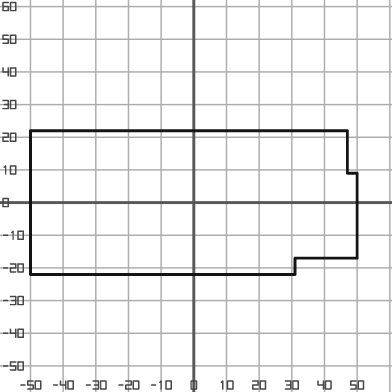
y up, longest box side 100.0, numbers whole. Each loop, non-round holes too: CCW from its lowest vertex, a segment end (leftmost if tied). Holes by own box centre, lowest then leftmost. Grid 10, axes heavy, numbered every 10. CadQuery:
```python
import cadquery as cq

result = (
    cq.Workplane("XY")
    .moveTo(-50.0, -22.0)
    .lineTo(31.0, -22.0)
    .lineTo(31.0, -17.0)
    .lineTo(50.0, -17.0)
    .lineTo(50.0, 9.0)
    .lineTo(47.0, 9.0)
    .lineTo(47.0, 22.0)
    .lineTo(-50.0, 22.0)
    .close()
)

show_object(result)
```